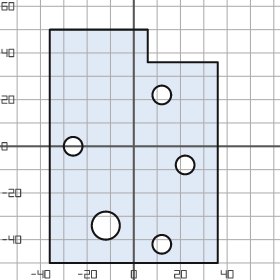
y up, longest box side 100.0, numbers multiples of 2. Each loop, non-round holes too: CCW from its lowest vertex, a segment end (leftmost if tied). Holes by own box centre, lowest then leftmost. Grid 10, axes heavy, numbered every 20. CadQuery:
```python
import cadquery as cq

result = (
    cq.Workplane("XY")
    .moveTo(-36.0, -50.0)
    .lineTo(36.0, -50.0)
    .lineTo(36.0, 36.0)
    .lineTo(6.0, 36.0)
    .lineTo(6.0, 50.0)
    .lineTo(-36.0, 50.0)
    .close()
    .moveTo(12.0, -42.0)
    .circle(4.0)
    .moveTo(-12.0, -34.0)
    .circle(6.0)
    .moveTo(22.0, -8.0)
    .circle(4.0)
    .moveTo(-26.0, 0.0)
    .circle(4.0)
    .moveTo(12.0, 22.0)
    .circle(4.0)
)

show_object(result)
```